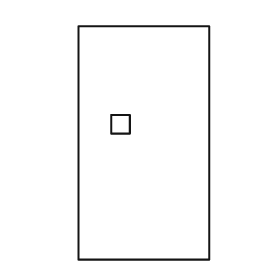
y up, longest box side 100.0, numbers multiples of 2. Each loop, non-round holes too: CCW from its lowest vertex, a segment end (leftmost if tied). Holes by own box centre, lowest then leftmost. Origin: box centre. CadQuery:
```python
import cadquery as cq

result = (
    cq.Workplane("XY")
    .moveTo(-28.0, -50.0)
    .lineTo(28.0, -50.0)
    .lineTo(28.0, 50.0)
    .lineTo(-28.0, 50.0)
    .close()
    .moveTo(-14.0, 4.0)
    .lineTo(-6.0, 4.0)
    .lineTo(-6.0, 12.0)
    .lineTo(-14.0, 12.0)
    .close()
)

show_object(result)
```